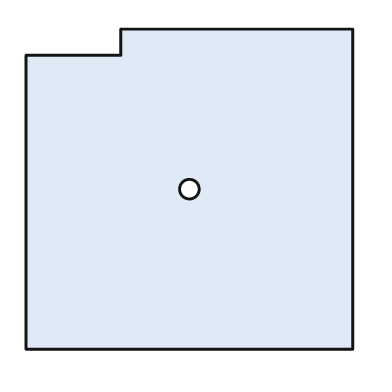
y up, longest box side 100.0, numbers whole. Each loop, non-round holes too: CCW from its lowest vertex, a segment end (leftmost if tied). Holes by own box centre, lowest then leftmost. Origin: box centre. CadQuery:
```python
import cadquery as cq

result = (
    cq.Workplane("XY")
    .moveTo(-50.0, -49.0)
    .lineTo(50.0, -49.0)
    .lineTo(50.0, 49.0)
    .lineTo(-21.0, 49.0)
    .lineTo(-21.0, 41.0)
    .lineTo(-50.0, 41.0)
    .close()
    .moveTo(0.0, 0.0)
    .circle(3.0)
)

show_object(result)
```